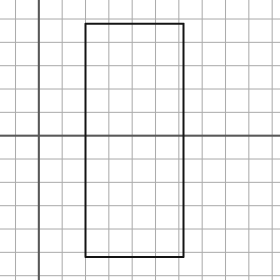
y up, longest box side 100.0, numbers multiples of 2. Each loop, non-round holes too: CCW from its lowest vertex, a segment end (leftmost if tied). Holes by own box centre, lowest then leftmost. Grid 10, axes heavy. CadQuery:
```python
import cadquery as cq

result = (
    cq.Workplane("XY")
    .moveTo(20.0, -52.0)
    .lineTo(62.0, -52.0)
    .lineTo(62.0, 48.0)
    .lineTo(20.0, 48.0)
    .close()
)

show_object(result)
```